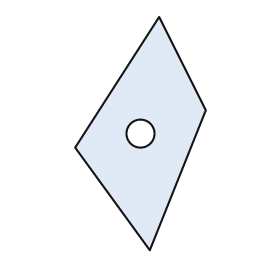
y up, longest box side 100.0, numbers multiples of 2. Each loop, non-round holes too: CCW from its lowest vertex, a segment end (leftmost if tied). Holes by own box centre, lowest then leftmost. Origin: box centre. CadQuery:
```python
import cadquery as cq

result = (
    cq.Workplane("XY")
    .moveTo(4.0, -50.0)
    .lineTo(28.0, 10.0)
    .lineTo(8.0, 50.0)
    .lineTo(-28.0, -6.0)
    .close()
    .moveTo(0.0, 0.0)
    .circle(6.0)
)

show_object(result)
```